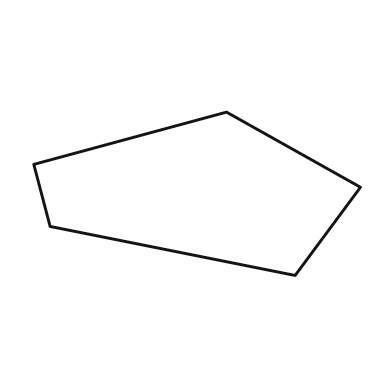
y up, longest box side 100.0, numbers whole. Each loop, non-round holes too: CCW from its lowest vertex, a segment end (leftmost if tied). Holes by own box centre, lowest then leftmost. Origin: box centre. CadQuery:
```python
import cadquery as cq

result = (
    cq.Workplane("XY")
    .moveTo(30.0, -25.0)
    .lineTo(50.0, 2.0)
    .lineTo(9.0, 25.0)
    .lineTo(-50.0, 9.0)
    .lineTo(-45.0, -10.0)
    .close()
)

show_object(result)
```